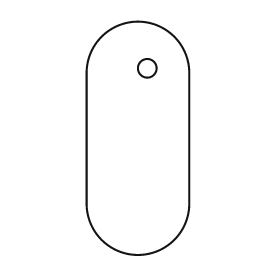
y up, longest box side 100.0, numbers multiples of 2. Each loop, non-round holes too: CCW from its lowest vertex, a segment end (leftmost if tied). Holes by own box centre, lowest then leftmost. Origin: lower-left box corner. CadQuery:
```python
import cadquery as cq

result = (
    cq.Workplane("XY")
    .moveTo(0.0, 22.0)
    .threePointArc((22.0, 0.0), (44.0, 22.0))
    .lineTo(44.0, 78.0)
    .threePointArc((22.0, 100.0), (0.0, 78.0))
    .close()
    .moveTo(26.0, 80.0)
    .circle(4.0)
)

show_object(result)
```